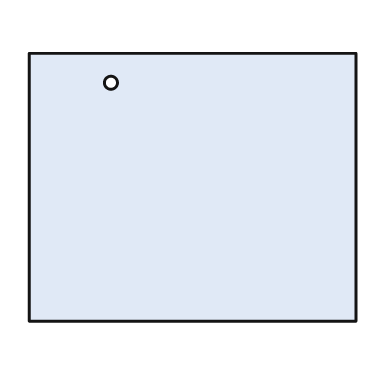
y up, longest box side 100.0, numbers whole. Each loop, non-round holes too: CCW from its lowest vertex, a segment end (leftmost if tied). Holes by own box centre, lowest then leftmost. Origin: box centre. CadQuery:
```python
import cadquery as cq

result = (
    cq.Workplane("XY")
    .moveTo(-50.0, -41.0)
    .lineTo(50.0, -41.0)
    .lineTo(50.0, 41.0)
    .lineTo(-50.0, 41.0)
    .close()
    .moveTo(-25.0, 32.0)
    .circle(2.0)
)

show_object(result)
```